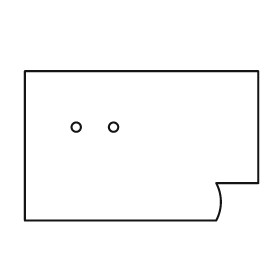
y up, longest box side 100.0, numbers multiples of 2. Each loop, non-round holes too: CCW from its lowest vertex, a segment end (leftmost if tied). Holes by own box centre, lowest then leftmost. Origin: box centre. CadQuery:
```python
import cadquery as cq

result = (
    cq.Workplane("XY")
    .moveTo(-50.0, -32.0)
    .lineTo(32.0, -32.0)
    .threePointArc((34.0, -24.0), (32.0, -16.0))
    .lineTo(50.0, -16.0)
    .lineTo(50.0, 32.0)
    .lineTo(-50.0, 32.0)
    .close()
    .moveTo(-28.0, 8.0)
    .circle(2.0)
    .moveTo(-12.0, 8.0)
    .circle(2.0)
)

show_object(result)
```